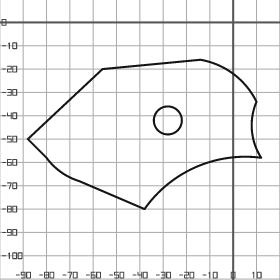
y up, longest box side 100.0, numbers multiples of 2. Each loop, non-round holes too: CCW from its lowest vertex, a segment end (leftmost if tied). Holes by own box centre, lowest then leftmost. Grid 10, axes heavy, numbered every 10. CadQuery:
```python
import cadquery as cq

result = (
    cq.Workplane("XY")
    .moveTo(-38.0, -80.0)
    .threePointArc((-16.0, -62.0), (12.0, -58.0))
    .threePointArc((8.0, -46.0), (10.0, -34.0))
    .threePointArc((0.0, -22.0), (-14.0, -16.0))
    .lineTo(-56.0, -20.0)
    .lineTo(-88.0, -50.0)
    .lineTo(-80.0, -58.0)
    .threePointArc((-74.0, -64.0), (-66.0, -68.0))
    .close()
    .moveTo(-28.0, -42.0)
    .circle(6.0)
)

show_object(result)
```